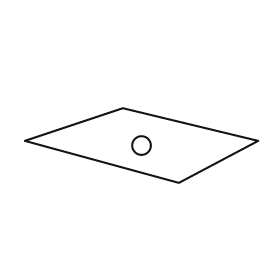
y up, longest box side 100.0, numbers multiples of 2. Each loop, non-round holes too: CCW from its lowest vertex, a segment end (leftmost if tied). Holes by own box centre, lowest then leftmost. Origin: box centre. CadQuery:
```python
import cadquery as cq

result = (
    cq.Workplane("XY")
    .moveTo(16.0, -16.0)
    .lineTo(50.0, 2.0)
    .lineTo(-8.0, 16.0)
    .lineTo(-50.0, 2.0)
    .close()
    .moveTo(0.0, 0.0)
    .circle(4.0)
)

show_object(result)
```